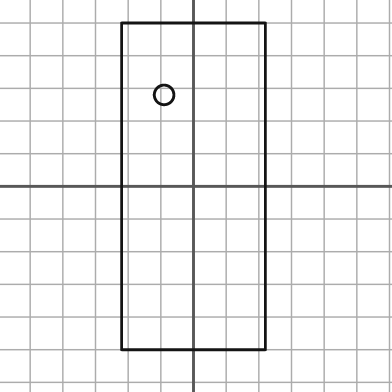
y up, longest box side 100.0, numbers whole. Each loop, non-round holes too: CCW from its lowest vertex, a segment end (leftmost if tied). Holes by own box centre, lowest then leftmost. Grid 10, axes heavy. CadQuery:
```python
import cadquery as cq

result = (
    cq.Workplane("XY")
    .moveTo(-22.0, -50.0)
    .lineTo(22.0, -50.0)
    .lineTo(22.0, 50.0)
    .lineTo(-22.0, 50.0)
    .close()
    .moveTo(-9.0, 28.0)
    .circle(3.0)
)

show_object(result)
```